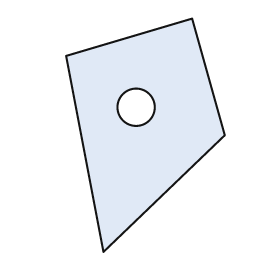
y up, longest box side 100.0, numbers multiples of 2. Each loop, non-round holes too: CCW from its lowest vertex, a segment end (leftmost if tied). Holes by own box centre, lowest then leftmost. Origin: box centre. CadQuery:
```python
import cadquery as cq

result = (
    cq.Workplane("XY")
    .moveTo(-18.0, -50.0)
    .lineTo(34.0, 0.0)
    .lineTo(20.0, 50.0)
    .lineTo(-34.0, 34.0)
    .close()
    .moveTo(-4.0, 12.0)
    .circle(8.0)
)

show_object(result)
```